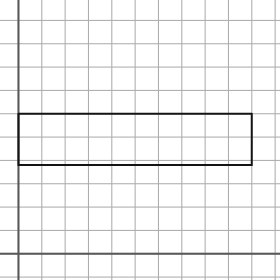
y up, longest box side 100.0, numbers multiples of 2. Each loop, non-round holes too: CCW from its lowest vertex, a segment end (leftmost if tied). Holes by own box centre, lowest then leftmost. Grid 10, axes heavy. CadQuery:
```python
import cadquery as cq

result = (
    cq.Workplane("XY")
    .moveTo(0.0, 38.0)
    .lineTo(100.0, 38.0)
    .lineTo(100.0, 60.0)
    .lineTo(0.0, 60.0)
    .close()
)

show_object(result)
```